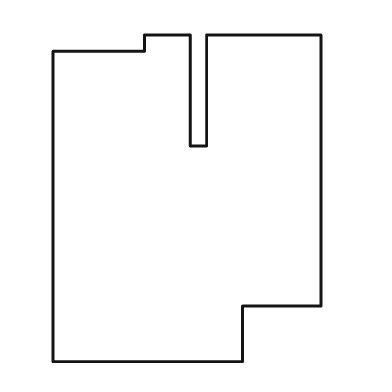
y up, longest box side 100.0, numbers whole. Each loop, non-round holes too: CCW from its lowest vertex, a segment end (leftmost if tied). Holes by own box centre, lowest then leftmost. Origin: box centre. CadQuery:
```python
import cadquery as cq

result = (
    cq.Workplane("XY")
    .moveTo(-41.0, -50.0)
    .lineTo(17.0, -50.0)
    .lineTo(17.0, -33.0)
    .lineTo(41.0, -33.0)
    .lineTo(41.0, 50.0)
    .lineTo(6.0, 50.0)
    .lineTo(6.0, 16.0)
    .lineTo(1.0, 16.0)
    .lineTo(1.0, 50.0)
    .lineTo(-13.0, 50.0)
    .lineTo(-13.0, 45.0)
    .lineTo(-41.0, 45.0)
    .close()
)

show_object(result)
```